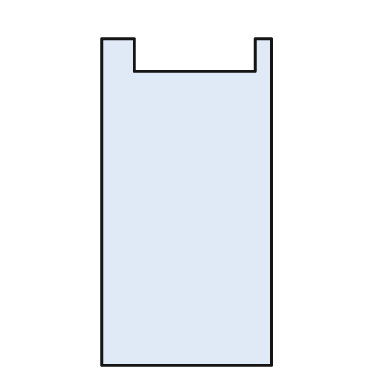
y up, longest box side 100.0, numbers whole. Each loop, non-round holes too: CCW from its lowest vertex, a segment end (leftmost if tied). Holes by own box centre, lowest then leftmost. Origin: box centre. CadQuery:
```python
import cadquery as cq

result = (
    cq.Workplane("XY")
    .moveTo(-26.0, -50.0)
    .lineTo(26.0, -50.0)
    .lineTo(26.0, 50.0)
    .lineTo(21.0, 50.0)
    .lineTo(21.0, 40.0)
    .lineTo(-16.0, 40.0)
    .lineTo(-16.0, 50.0)
    .lineTo(-26.0, 50.0)
    .close()
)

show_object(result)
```